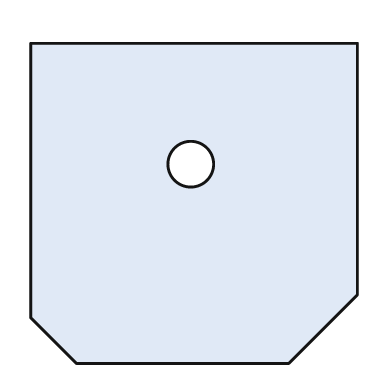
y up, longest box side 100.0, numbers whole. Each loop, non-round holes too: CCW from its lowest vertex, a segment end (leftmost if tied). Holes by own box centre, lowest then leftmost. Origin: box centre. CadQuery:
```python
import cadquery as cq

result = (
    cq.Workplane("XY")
    .moveTo(-36.0, -49.0)
    .lineTo(29.0, -49.0)
    .lineTo(50.0, -28.0)
    .lineTo(50.0, 49.0)
    .lineTo(-50.0, 49.0)
    .lineTo(-50.0, -35.0)
    .close()
    .moveTo(-1.0, 12.0)
    .circle(7.0)
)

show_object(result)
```